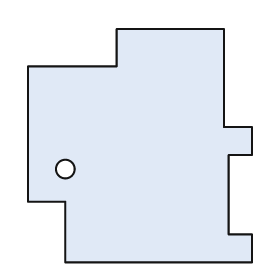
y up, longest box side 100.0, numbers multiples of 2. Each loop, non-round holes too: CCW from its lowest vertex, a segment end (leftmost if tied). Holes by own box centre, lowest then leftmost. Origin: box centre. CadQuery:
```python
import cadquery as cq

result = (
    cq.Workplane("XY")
    .moveTo(-32.0, -50.0)
    .lineTo(48.0, -50.0)
    .lineTo(48.0, -38.0)
    .lineTo(38.0, -38.0)
    .lineTo(38.0, -4.0)
    .lineTo(48.0, -4.0)
    .lineTo(48.0, 8.0)
    .lineTo(36.0, 8.0)
    .lineTo(36.0, 50.0)
    .lineTo(-10.0, 50.0)
    .lineTo(-10.0, 34.0)
    .lineTo(-48.0, 34.0)
    .lineTo(-48.0, -24.0)
    .lineTo(-32.0, -24.0)
    .close()
    .moveTo(-32.0, -10.0)
    .circle(4.0)
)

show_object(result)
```